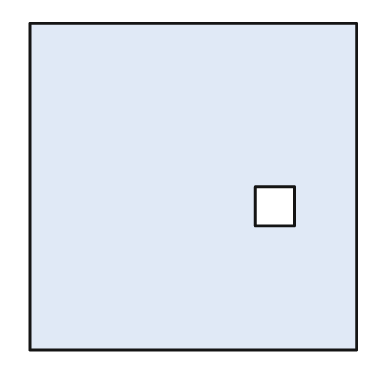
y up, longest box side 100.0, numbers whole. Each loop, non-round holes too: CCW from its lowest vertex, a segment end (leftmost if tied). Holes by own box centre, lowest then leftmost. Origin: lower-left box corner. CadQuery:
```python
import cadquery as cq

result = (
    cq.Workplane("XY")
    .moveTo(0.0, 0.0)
    .lineTo(100.0, 0.0)
    .lineTo(100.0, 100.0)
    .lineTo(0.0, 100.0)
    .close()
    .moveTo(69.0, 38.0)
    .lineTo(81.0, 38.0)
    .lineTo(81.0, 50.0)
    .lineTo(69.0, 50.0)
    .close()
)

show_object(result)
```